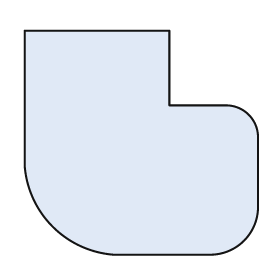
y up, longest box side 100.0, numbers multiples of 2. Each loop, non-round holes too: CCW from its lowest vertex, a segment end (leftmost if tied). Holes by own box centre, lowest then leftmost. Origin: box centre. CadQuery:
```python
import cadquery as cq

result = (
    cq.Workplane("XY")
    .moveTo(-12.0, -48.0)
    .lineTo(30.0, -48.0)
    .threePointArc((44.0, -42.0), (50.0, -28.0))
    .lineTo(50.0, 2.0)
    .threePointArc((46.0, 12.0), (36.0, 16.0))
    .lineTo(12.0, 16.0)
    .lineTo(12.0, 48.0)
    .lineTo(-50.0, 48.0)
    .lineTo(-50.0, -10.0)
    .threePointArc((-38.0, -36.0), (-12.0, -48.0))
    .close()
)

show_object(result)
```